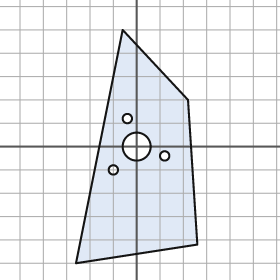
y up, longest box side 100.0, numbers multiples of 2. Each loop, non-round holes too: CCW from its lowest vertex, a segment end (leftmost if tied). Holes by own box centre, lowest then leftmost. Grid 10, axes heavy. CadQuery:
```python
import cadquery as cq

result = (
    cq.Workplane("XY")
    .moveTo(-26.0, -50.0)
    .lineTo(26.0, -42.0)
    .lineTo(22.0, 20.0)
    .lineTo(-6.0, 50.0)
    .close()
    .moveTo(-10.0, -10.0)
    .circle(2.0)
    .moveTo(12.0, -4.0)
    .circle(2.0)
    .moveTo(0.0, 0.0)
    .circle(6.0)
    .moveTo(-4.0, 12.0)
    .circle(2.0)
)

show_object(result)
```